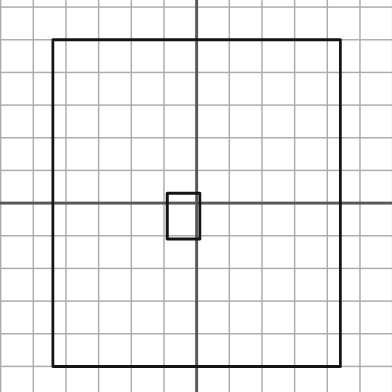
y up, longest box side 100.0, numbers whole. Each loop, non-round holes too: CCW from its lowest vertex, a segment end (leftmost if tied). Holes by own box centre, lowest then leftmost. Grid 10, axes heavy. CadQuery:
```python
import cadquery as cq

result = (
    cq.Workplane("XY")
    .moveTo(-44.0, -50.0)
    .lineTo(44.0, -50.0)
    .lineTo(44.0, 50.0)
    .lineTo(-44.0, 50.0)
    .close()
    .moveTo(-9.0, -11.0)
    .lineTo(1.0, -11.0)
    .lineTo(1.0, 3.0)
    .lineTo(-9.0, 3.0)
    .close()
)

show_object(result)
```